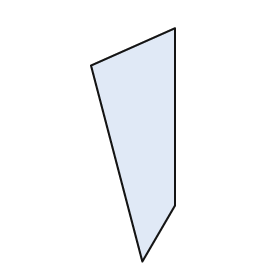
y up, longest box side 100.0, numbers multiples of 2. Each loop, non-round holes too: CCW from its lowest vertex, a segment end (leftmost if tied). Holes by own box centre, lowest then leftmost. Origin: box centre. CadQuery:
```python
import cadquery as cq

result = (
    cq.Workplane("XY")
    .moveTo(4.0, -50.0)
    .lineTo(18.0, -26.0)
    .lineTo(18.0, 50.0)
    .lineTo(-18.0, 34.0)
    .close()
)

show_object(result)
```